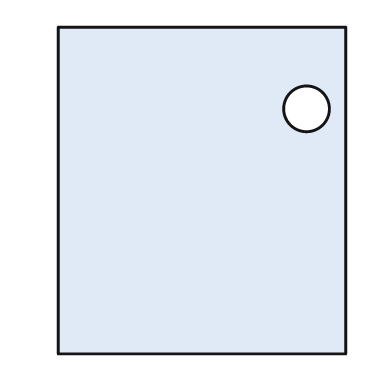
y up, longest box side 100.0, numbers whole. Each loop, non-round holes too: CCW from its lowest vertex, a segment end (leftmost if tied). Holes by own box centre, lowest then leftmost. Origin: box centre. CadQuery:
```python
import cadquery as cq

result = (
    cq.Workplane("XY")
    .moveTo(-44.0, -50.0)
    .lineTo(44.0, -50.0)
    .lineTo(44.0, 50.0)
    .lineTo(-44.0, 50.0)
    .close()
    .moveTo(32.0, 25.0)
    .circle(7.0)
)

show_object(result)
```